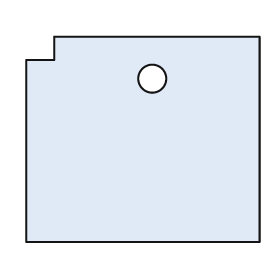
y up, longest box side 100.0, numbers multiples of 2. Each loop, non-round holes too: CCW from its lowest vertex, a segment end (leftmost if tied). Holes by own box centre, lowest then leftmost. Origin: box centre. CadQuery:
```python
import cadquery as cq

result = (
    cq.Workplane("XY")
    .moveTo(-50.0, -44.0)
    .lineTo(50.0, -44.0)
    .lineTo(50.0, 44.0)
    .lineTo(-38.0, 44.0)
    .lineTo(-38.0, 34.0)
    .lineTo(-50.0, 34.0)
    .close()
    .moveTo(4.0, 26.0)
    .circle(6.0)
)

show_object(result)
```